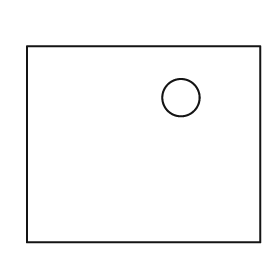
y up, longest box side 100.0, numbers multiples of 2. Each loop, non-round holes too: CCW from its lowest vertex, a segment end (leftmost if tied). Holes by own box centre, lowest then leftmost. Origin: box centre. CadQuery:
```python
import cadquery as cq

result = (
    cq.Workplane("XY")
    .moveTo(-50.0, -42.0)
    .lineTo(50.0, -42.0)
    .lineTo(50.0, 42.0)
    .lineTo(-50.0, 42.0)
    .close()
    .moveTo(16.0, 20.0)
    .circle(8.0)
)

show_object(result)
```